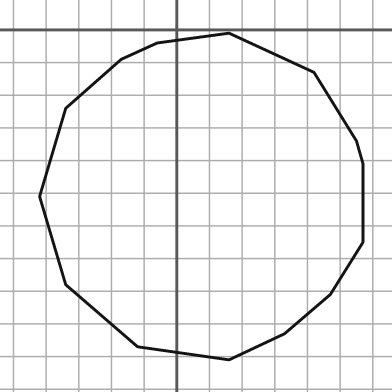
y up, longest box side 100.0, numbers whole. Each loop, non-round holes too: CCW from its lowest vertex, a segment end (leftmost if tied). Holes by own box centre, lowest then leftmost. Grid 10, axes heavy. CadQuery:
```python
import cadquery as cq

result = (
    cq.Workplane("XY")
    .moveTo(16.0, -101.0)
    .lineTo(33.0, -93.0)
    .lineTo(47.0, -81.0)
    .lineTo(57.0, -65.0)
    .lineTo(57.0, -41.0)
    .lineTo(55.0, -34.0)
    .lineTo(42.0, -13.0)
    .lineTo(16.0, -1.0)
    .lineTo(-6.0, -4.0)
    .lineTo(-17.0, -9.0)
    .lineTo(-34.0, -24.0)
    .lineTo(-42.0, -51.0)
    .lineTo(-34.0, -78.0)
    .lineTo(-12.0, -97.0)
    .close()
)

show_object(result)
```